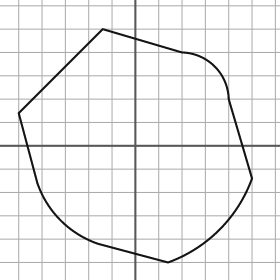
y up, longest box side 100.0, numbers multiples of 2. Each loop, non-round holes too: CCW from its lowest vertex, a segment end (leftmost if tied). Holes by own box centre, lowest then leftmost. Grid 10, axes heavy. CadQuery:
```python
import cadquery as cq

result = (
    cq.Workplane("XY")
    .moveTo(14.0, -50.0)
    .threePointArc((36.0, -36.0), (50.0, -14.0))
    .lineTo(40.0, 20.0)
    .threePointArc((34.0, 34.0), (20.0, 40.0))
    .lineTo(-14.0, 50.0)
    .lineTo(-50.0, 14.0)
    .lineTo(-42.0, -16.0)
    .threePointArc((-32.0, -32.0), (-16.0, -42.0))
    .close()
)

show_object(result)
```